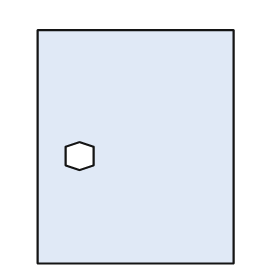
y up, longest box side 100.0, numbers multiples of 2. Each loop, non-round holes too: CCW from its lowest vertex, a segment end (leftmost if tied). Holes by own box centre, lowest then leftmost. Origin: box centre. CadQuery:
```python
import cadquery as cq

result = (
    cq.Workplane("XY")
    .moveTo(-42.0, -50.0)
    .lineTo(42.0, -50.0)
    .lineTo(42.0, 50.0)
    .lineTo(-42.0, 50.0)
    .close()
    .moveTo(-24.0, -10.0)
    .lineTo(-18.0, -8.0)
    .lineTo(-18.0, 0.0)
    .lineTo(-24.0, 2.0)
    .lineTo(-30.0, 0.0)
    .lineTo(-30.0, -8.0)
    .close()
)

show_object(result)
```